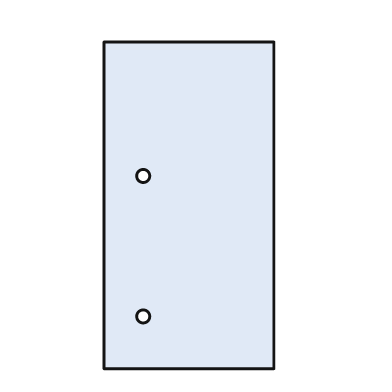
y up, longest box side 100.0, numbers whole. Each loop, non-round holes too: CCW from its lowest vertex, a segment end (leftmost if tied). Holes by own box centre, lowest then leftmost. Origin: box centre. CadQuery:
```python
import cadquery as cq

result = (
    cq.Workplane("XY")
    .moveTo(-26.0, -50.0)
    .lineTo(26.0, -50.0)
    .lineTo(26.0, 50.0)
    .lineTo(-26.0, 50.0)
    .close()
    .moveTo(-14.0, -34.0)
    .circle(2.0)
    .moveTo(-14.0, 9.0)
    .circle(2.0)
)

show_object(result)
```